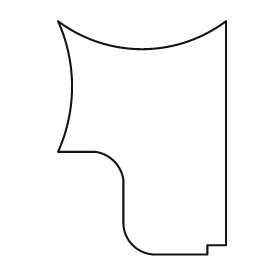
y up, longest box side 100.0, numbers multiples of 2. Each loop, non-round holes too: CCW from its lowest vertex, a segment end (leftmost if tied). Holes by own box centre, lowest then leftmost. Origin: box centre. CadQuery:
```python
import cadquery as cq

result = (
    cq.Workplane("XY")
    .moveTo(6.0, -50.0)
    .lineTo(28.0, -50.0)
    .lineTo(28.0, -46.0)
    .lineTo(36.0, -46.0)
    .lineTo(36.0, 50.0)
    .threePointArc((0.0, 38.0), (-36.0, 50.0))
    .threePointArc((-30.0, 22.0), (-36.0, -6.0))
    .lineTo(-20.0, -6.0)
    .threePointArc((-12.0, -10.0), (-8.0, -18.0))
    .lineTo(-8.0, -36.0)
    .threePointArc((-4.0, -46.0), (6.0, -50.0))
    .close()
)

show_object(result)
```